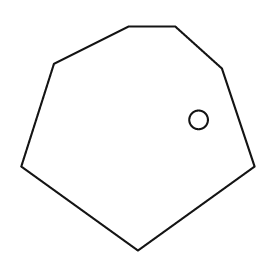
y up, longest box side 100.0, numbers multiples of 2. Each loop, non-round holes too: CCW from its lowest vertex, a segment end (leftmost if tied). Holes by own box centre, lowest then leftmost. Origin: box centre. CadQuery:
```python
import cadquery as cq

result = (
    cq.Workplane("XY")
    .moveTo(0.0, -48.0)
    .lineTo(50.0, -12.0)
    .lineTo(36.0, 30.0)
    .lineTo(16.0, 48.0)
    .lineTo(-4.0, 48.0)
    .lineTo(-36.0, 32.0)
    .lineTo(-50.0, -12.0)
    .close()
    .moveTo(26.0, 8.0)
    .circle(4.0)
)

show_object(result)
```